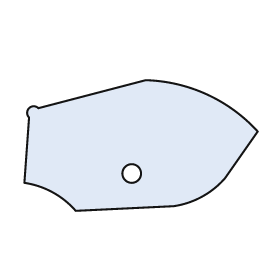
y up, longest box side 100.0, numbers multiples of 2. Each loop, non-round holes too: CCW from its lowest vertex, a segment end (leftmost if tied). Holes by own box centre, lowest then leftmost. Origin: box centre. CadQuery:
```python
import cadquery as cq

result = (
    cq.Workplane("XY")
    .moveTo(-28.0, -28.0)
    .lineTo(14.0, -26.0)
    .threePointArc((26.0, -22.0), (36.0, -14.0))
    .lineTo(50.0, 6.0)
    .threePointArc((28.0, 22.0), (2.0, 28.0))
    .lineTo(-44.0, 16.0)
    .threePointArc((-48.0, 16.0), (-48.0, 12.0))
    .lineTo(-50.0, -16.0)
    .threePointArc((-38.0, -20.0), (-28.0, -28.0))
    .close()
    .moveTo(-4.0, -12.0)
    .circle(4.0)
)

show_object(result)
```